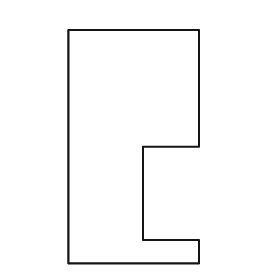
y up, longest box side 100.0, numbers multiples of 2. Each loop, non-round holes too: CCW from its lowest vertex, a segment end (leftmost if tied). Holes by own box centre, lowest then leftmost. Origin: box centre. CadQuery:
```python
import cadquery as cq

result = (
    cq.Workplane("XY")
    .moveTo(-28.0, -50.0)
    .lineTo(28.0, -50.0)
    .lineTo(28.0, -40.0)
    .lineTo(4.0, -40.0)
    .lineTo(4.0, 0.0)
    .lineTo(28.0, 0.0)
    .lineTo(28.0, 50.0)
    .lineTo(-28.0, 50.0)
    .close()
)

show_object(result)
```